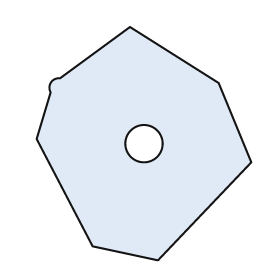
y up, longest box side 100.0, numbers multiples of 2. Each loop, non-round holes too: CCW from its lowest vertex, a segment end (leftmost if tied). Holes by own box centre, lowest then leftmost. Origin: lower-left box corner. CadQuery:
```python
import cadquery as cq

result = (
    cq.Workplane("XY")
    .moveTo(52.0, 0.0)
    .lineTo(92.0, 42.0)
    .lineTo(78.0, 76.0)
    .lineTo(40.0, 100.0)
    .lineTo(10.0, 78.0)
    .threePointArc((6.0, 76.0), (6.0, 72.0))
    .lineTo(0.0, 52.0)
    .lineTo(24.0, 6.0)
    .close()
    .moveTo(46.0, 50.0)
    .circle(8.0)
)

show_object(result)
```